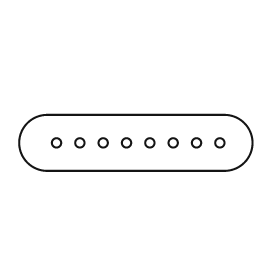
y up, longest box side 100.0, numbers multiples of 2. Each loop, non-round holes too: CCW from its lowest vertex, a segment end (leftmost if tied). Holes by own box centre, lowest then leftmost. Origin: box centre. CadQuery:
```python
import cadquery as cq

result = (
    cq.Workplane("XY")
    .moveTo(-38.0, -12.0)
    .lineTo(38.0, -12.0)
    .threePointArc((50.0, 0.0), (38.0, 12.0))
    .lineTo(-38.0, 12.0)
    .threePointArc((-50.0, 0.0), (-38.0, -12.0))
    .close()
    .moveTo(-34.0, 0.0)
    .circle(2.0)
    .moveTo(-24.0, 0.0)
    .circle(2.0)
    .moveTo(-14.0, 0.0)
    .circle(2.0)
    .moveTo(-4.0, 0.0)
    .circle(2.0)
    .moveTo(6.0, 0.0)
    .circle(2.0)
    .moveTo(16.0, 0.0)
    .circle(2.0)
    .moveTo(26.0, 0.0)
    .circle(2.0)
    .moveTo(36.0, 0.0)
    .circle(2.0)
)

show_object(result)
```